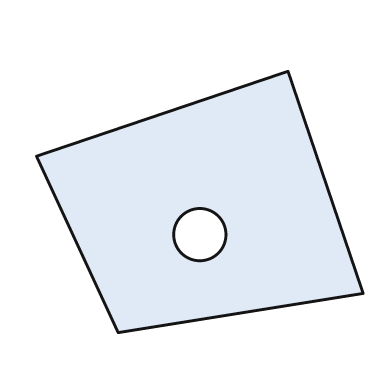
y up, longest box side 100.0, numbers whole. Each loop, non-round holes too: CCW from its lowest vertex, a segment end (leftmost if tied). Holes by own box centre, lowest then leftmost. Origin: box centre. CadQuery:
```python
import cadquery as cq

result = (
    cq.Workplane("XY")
    .moveTo(-25.0, -40.0)
    .lineTo(50.0, -28.0)
    .lineTo(27.0, 40.0)
    .lineTo(-50.0, 14.0)
    .close()
    .moveTo(0.0, -10.0)
    .circle(8.0)
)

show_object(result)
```